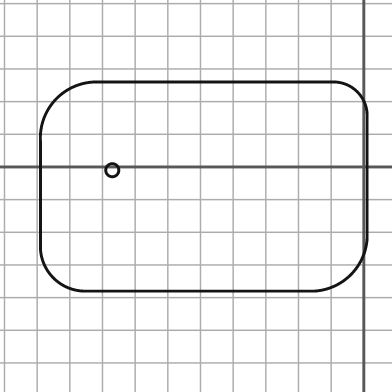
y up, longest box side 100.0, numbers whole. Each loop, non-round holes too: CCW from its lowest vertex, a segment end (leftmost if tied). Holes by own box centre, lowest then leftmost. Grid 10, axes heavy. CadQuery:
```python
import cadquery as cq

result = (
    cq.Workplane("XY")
    .moveTo(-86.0, -38.0)
    .lineTo(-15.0, -38.0)
    .threePointArc((-4.0, -33.0), (1.0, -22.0))
    .lineTo(1.0, 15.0)
    .threePointArc((-2.0, 23.0), (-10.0, 26.0))
    .lineTo(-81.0, 26.0)
    .threePointArc((-94.0, 21.0), (-99.0, 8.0))
    .lineTo(-99.0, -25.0)
    .threePointArc((-95.0, -34.0), (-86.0, -38.0))
    .close()
    .moveTo(-77.0, -1.0)
    .circle(2.0)
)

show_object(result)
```